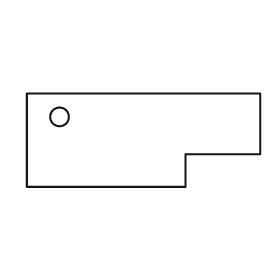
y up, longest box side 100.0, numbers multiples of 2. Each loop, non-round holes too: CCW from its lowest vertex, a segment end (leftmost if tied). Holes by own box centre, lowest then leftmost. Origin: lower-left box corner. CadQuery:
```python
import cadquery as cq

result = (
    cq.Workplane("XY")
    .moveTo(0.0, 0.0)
    .lineTo(68.0, 0.0)
    .lineTo(68.0, 14.0)
    .lineTo(100.0, 14.0)
    .lineTo(100.0, 40.0)
    .lineTo(0.0, 40.0)
    .close()
    .moveTo(14.0, 30.0)
    .circle(4.0)
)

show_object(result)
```